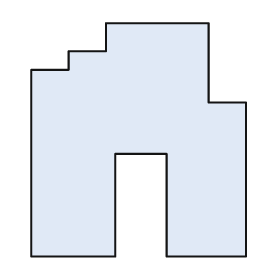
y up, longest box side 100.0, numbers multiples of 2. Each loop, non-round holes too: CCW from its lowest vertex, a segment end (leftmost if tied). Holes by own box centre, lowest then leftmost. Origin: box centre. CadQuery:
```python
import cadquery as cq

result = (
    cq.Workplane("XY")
    .moveTo(-46.0, -50.0)
    .lineTo(-10.0, -50.0)
    .lineTo(-10.0, -6.0)
    .lineTo(12.0, -6.0)
    .lineTo(12.0, -50.0)
    .lineTo(46.0, -50.0)
    .lineTo(46.0, 16.0)
    .lineTo(30.0, 16.0)
    .lineTo(30.0, 50.0)
    .lineTo(-14.0, 50.0)
    .lineTo(-14.0, 38.0)
    .lineTo(-30.0, 38.0)
    .lineTo(-30.0, 30.0)
    .lineTo(-46.0, 30.0)
    .close()
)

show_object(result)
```